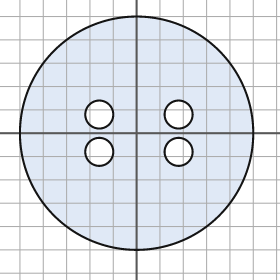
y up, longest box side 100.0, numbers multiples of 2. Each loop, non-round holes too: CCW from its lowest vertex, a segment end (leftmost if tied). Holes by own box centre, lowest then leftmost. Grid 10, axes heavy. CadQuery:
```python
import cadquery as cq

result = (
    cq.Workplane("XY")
    .moveTo(0.0, 0.0)
    .circle(50.0)
    .moveTo(-16.0, -8.0)
    .circle(6.0)
    .moveTo(18.0, -8.0)
    .circle(6.0)
    .moveTo(-16.0, 8.0)
    .circle(6.0)
    .moveTo(18.0, 8.0)
    .circle(6.0)
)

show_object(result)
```